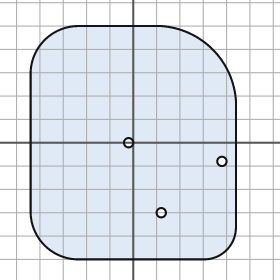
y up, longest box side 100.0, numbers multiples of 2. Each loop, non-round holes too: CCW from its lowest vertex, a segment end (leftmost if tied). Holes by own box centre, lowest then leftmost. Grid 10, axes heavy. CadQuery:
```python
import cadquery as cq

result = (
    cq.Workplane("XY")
    .moveTo(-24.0, -50.0)
    .lineTo(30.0, -50.0)
    .threePointArc((40.0, -46.0), (44.0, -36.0))
    .lineTo(44.0, 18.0)
    .threePointArc((34.0, 40.0), (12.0, 50.0))
    .lineTo(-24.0, 50.0)
    .threePointArc((-38.0, 44.0), (-44.0, 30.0))
    .lineTo(-44.0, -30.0)
    .threePointArc((-38.0, -44.0), (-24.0, -50.0))
    .close()
    .moveTo(12.0, -30.0)
    .circle(2.0)
    .moveTo(38.0, -8.0)
    .circle(2.0)
    .moveTo(-2.0, 0.0)
    .circle(2.0)
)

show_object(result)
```